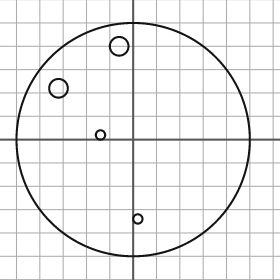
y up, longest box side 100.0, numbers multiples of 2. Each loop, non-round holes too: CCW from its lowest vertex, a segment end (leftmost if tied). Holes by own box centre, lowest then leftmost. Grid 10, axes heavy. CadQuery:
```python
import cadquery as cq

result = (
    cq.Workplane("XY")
    .moveTo(0.0, 0.0)
    .circle(50.0)
    .moveTo(2.0, -34.0)
    .circle(2.0)
    .moveTo(-14.0, 2.0)
    .circle(2.0)
    .moveTo(-32.0, 22.0)
    .circle(4.0)
    .moveTo(-6.0, 40.0)
    .circle(4.0)
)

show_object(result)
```